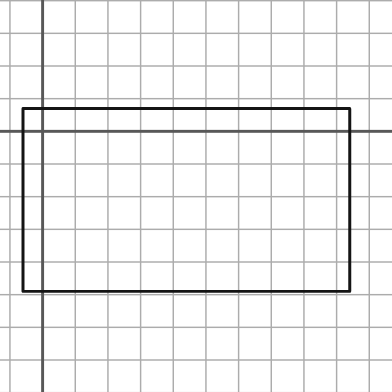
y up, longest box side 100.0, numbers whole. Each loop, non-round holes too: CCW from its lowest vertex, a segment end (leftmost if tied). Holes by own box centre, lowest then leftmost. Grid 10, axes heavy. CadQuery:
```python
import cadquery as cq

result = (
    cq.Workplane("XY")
    .moveTo(-6.0, -49.0)
    .lineTo(94.0, -49.0)
    .lineTo(94.0, 7.0)
    .lineTo(-6.0, 7.0)
    .close()
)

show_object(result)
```